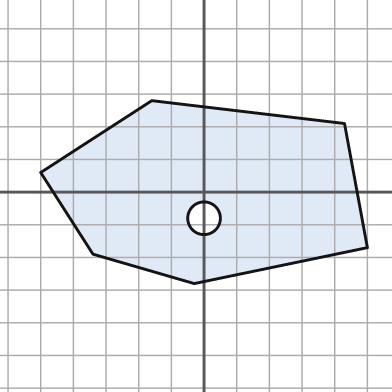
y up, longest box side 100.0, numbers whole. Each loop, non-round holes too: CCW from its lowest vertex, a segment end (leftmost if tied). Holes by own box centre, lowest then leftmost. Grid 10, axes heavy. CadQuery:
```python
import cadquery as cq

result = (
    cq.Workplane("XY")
    .moveTo(-3.0, -28.0)
    .lineTo(50.0, -17.0)
    .lineTo(43.0, 21.0)
    .lineTo(-16.0, 28.0)
    .lineTo(-50.0, 6.0)
    .lineTo(-34.0, -19.0)
    .close()
    .moveTo(0.0, -8.0)
    .circle(5.0)
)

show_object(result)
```